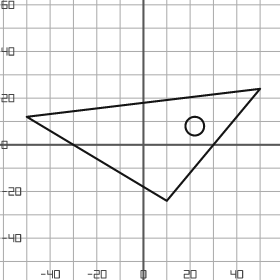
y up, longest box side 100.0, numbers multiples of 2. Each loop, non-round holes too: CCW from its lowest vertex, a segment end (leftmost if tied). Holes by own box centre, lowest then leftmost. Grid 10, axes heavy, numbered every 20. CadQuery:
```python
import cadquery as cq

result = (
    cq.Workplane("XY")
    .moveTo(10.0, -24.0)
    .lineTo(50.0, 24.0)
    .lineTo(-50.0, 12.0)
    .close()
    .moveTo(22.0, 8.0)
    .circle(4.0)
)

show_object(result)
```